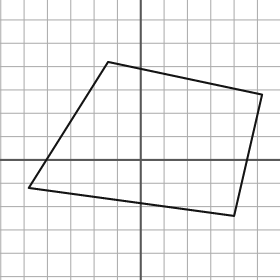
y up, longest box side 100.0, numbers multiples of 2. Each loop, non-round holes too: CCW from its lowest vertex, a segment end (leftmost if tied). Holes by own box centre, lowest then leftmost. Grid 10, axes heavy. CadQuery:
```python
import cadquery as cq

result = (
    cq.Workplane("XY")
    .moveTo(40.0, -24.0)
    .lineTo(52.0, 28.0)
    .lineTo(-14.0, 42.0)
    .lineTo(-48.0, -12.0)
    .close()
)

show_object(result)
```